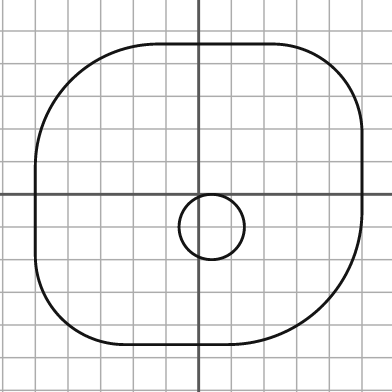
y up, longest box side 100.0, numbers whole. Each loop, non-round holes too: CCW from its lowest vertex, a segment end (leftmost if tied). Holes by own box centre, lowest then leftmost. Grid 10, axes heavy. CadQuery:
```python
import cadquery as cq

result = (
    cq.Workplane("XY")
    .moveTo(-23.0, -46.0)
    .lineTo(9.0, -46.0)
    .threePointArc((38.0, -34.0), (50.0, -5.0))
    .lineTo(50.0, 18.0)
    .threePointArc((42.0, 38.0), (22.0, 46.0))
    .lineTo(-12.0, 46.0)
    .threePointArc((-39.0, 35.0), (-50.0, 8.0))
    .lineTo(-50.0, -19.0)
    .threePointArc((-42.0, -38.0), (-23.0, -46.0))
    .close()
    .moveTo(4.0, -10.0)
    .circle(10.0)
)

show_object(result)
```